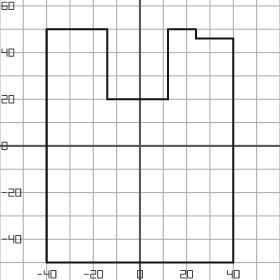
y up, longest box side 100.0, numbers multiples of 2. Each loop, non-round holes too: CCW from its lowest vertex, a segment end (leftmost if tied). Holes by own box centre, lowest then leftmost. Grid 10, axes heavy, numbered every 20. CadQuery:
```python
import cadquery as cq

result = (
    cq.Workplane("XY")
    .moveTo(-40.0, -50.0)
    .lineTo(40.0, -50.0)
    .lineTo(40.0, 46.0)
    .lineTo(24.0, 46.0)
    .lineTo(24.0, 50.0)
    .lineTo(12.0, 50.0)
    .lineTo(12.0, 20.0)
    .lineTo(-14.0, 20.0)
    .lineTo(-14.0, 50.0)
    .lineTo(-40.0, 50.0)
    .close()
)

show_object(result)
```